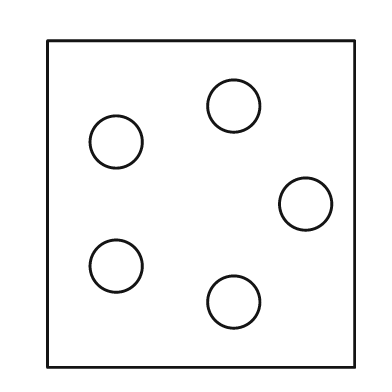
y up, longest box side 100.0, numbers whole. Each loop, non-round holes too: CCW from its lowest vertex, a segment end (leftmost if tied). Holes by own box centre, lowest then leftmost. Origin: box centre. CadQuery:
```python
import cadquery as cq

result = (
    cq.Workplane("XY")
    .moveTo(-47.0, -50.0)
    .lineTo(47.0, -50.0)
    .lineTo(47.0, 50.0)
    .lineTo(-47.0, 50.0)
    .close()
    .moveTo(10.0, -30.0)
    .circle(8.0)
    .moveTo(-26.0, -19.0)
    .circle(8.0)
    .moveTo(32.0, 0.0)
    .circle(8.0)
    .moveTo(-26.0, 19.0)
    .circle(8.0)
    .moveTo(10.0, 30.0)
    .circle(8.0)
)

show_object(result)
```